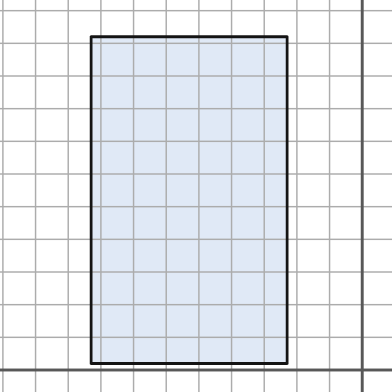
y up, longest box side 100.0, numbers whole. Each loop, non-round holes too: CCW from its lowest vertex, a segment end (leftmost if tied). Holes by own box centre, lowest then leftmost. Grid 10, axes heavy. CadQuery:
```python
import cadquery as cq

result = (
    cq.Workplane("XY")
    .moveTo(-83.0, 2.0)
    .lineTo(-23.0, 2.0)
    .lineTo(-23.0, 102.0)
    .lineTo(-83.0, 102.0)
    .close()
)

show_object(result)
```